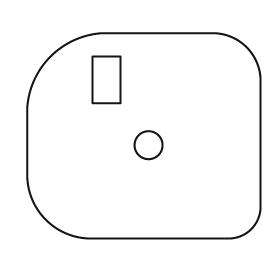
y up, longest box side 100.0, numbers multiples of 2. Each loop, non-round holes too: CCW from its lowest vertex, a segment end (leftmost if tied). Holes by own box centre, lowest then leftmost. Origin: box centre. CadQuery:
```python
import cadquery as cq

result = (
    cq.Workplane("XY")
    .moveTo(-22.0, -44.0)
    .lineTo(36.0, -44.0)
    .threePointArc((46.0, -40.0), (50.0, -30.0))
    .lineTo(50.0, 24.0)
    .threePointArc((44.0, 38.0), (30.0, 44.0))
    .lineTo(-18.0, 44.0)
    .threePointArc((-40.0, 34.0), (-50.0, 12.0))
    .lineTo(-50.0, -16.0)
    .threePointArc((-42.0, -36.0), (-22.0, -44.0))
    .close()
    .moveTo(2.0, -4.0)
    .circle(6.0)
    .moveTo(-22.0, 14.0)
    .lineTo(-10.0, 14.0)
    .lineTo(-10.0, 34.0)
    .lineTo(-22.0, 34.0)
    .close()
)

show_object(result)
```